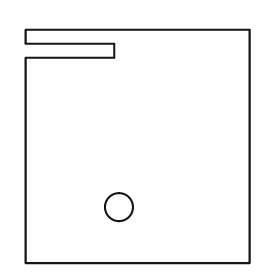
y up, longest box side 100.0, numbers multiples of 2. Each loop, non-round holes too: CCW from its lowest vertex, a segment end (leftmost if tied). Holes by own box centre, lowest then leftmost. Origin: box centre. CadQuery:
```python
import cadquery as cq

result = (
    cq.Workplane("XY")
    .moveTo(-48.0, -50.0)
    .lineTo(48.0, -50.0)
    .lineTo(48.0, 50.0)
    .lineTo(-48.0, 50.0)
    .lineTo(-48.0, 44.0)
    .lineTo(-10.0, 44.0)
    .lineTo(-10.0, 38.0)
    .lineTo(-48.0, 38.0)
    .close()
    .moveTo(-8.0, -26.0)
    .circle(6.0)
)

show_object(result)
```